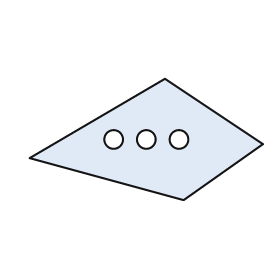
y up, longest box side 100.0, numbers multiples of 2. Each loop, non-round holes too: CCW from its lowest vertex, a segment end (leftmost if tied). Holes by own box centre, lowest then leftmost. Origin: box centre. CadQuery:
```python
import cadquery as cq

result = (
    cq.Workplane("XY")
    .moveTo(16.0, -26.0)
    .lineTo(50.0, -2.0)
    .lineTo(8.0, 26.0)
    .lineTo(-50.0, -8.0)
    .close()
    .moveTo(-14.0, 0.0)
    .circle(4.0)
    .moveTo(0.0, 0.0)
    .circle(4.0)
    .moveTo(14.0, 0.0)
    .circle(4.0)
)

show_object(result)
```